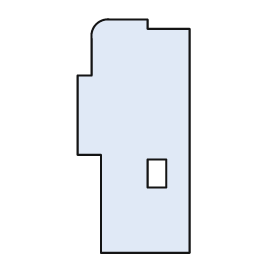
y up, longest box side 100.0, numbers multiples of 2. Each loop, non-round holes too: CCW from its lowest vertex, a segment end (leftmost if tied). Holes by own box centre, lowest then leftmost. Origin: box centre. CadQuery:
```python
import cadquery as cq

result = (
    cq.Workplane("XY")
    .moveTo(-14.0, -50.0)
    .lineTo(24.0, -50.0)
    .lineTo(24.0, 46.0)
    .lineTo(6.0, 46.0)
    .lineTo(6.0, 50.0)
    .lineTo(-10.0, 50.0)
    .threePointArc((-16.0, 48.0), (-18.0, 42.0))
    .lineTo(-18.0, 26.0)
    .lineTo(-24.0, 26.0)
    .lineTo(-24.0, -8.0)
    .lineTo(-14.0, -8.0)
    .close()
    .moveTo(6.0, -22.0)
    .lineTo(14.0, -22.0)
    .lineTo(14.0, -10.0)
    .lineTo(6.0, -10.0)
    .close()
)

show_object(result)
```